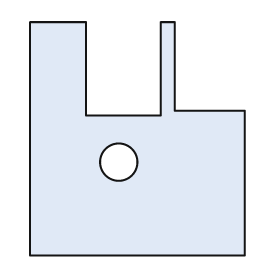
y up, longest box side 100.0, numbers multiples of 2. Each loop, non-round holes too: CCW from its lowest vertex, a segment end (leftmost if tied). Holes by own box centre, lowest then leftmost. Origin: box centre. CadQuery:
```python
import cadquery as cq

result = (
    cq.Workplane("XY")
    .moveTo(-46.0, -50.0)
    .lineTo(46.0, -50.0)
    .lineTo(46.0, 12.0)
    .lineTo(16.0, 12.0)
    .lineTo(16.0, 50.0)
    .lineTo(10.0, 50.0)
    .lineTo(10.0, 10.0)
    .lineTo(-22.0, 10.0)
    .lineTo(-22.0, 50.0)
    .lineTo(-46.0, 50.0)
    .close()
    .moveTo(-8.0, -10.0)
    .circle(8.0)
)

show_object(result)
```